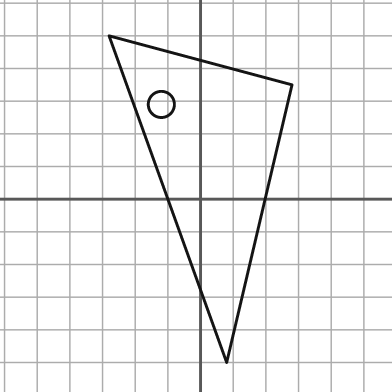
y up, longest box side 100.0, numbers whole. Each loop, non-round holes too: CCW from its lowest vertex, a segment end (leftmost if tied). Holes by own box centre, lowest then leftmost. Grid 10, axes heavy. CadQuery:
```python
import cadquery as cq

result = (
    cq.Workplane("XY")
    .moveTo(8.0, -50.0)
    .lineTo(28.0, 35.0)
    .lineTo(-28.0, 50.0)
    .close()
    .moveTo(-12.0, 29.0)
    .circle(4.0)
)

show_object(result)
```